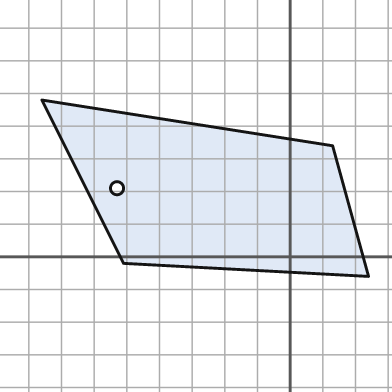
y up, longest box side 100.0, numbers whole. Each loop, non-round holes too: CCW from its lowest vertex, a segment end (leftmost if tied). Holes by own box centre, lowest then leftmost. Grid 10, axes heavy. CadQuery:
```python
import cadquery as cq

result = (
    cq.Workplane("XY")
    .moveTo(24.0, -6.0)
    .lineTo(13.0, 34.0)
    .lineTo(-76.0, 48.0)
    .lineTo(-51.0, -2.0)
    .close()
    .moveTo(-53.0, 21.0)
    .circle(2.0)
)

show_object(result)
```